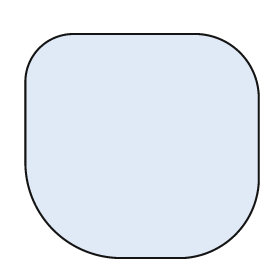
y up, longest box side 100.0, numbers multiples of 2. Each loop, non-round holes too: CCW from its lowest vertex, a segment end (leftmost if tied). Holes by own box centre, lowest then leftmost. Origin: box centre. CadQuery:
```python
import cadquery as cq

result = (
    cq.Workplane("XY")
    .moveTo(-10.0, -48.0)
    .lineTo(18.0, -48.0)
    .threePointArc((40.0, -38.0), (50.0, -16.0))
    .lineTo(50.0, 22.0)
    .threePointArc((42.0, 40.0), (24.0, 48.0))
    .lineTo(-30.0, 48.0)
    .threePointArc((-44.0, 42.0), (-50.0, 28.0))
    .lineTo(-50.0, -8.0)
    .threePointArc((-38.0, -36.0), (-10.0, -48.0))
    .close()
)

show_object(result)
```